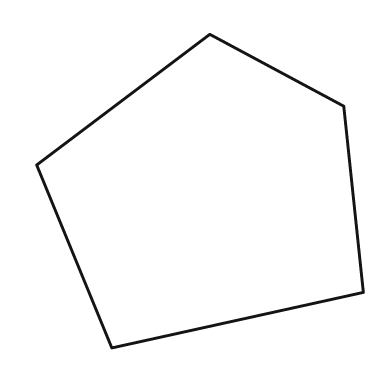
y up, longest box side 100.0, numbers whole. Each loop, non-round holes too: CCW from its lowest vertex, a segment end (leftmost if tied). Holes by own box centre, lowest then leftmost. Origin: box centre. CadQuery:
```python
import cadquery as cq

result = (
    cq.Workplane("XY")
    .moveTo(-27.0, -48.0)
    .lineTo(50.0, -31.0)
    .lineTo(44.0, 26.0)
    .lineTo(3.0, 48.0)
    .lineTo(-50.0, 8.0)
    .close()
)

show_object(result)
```